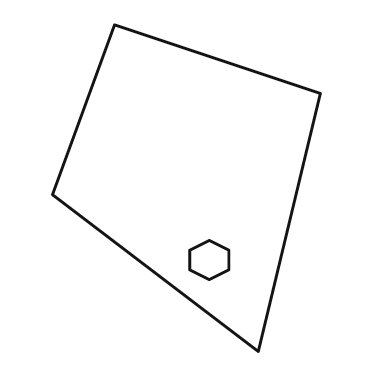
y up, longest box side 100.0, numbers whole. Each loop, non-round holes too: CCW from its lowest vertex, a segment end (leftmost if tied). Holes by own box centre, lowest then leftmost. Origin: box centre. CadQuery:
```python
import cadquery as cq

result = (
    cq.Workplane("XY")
    .moveTo(22.0, -50.0)
    .lineTo(41.0, 29.0)
    .lineTo(-22.0, 50.0)
    .lineTo(-41.0, -2.0)
    .close()
    .moveTo(7.0, -28.0)
    .lineTo(13.0, -25.0)
    .lineTo(13.0, -19.0)
    .lineTo(7.0, -16.0)
    .lineTo(1.0, -19.0)
    .lineTo(1.0, -25.0)
    .close()
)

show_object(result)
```